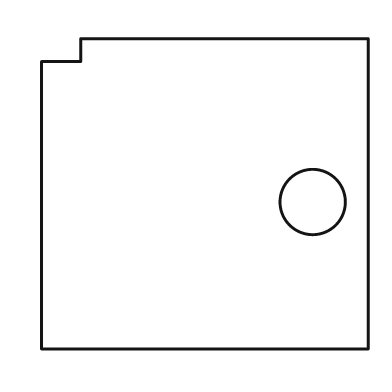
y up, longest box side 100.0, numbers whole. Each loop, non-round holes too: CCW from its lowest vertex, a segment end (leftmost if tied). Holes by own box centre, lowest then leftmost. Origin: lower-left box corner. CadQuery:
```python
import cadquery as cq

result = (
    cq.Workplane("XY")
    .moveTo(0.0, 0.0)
    .lineTo(100.0, 0.0)
    .lineTo(100.0, 95.0)
    .lineTo(12.0, 95.0)
    .lineTo(12.0, 88.0)
    .lineTo(0.0, 88.0)
    .close()
    .moveTo(83.0, 45.0)
    .circle(10.0)
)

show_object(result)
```